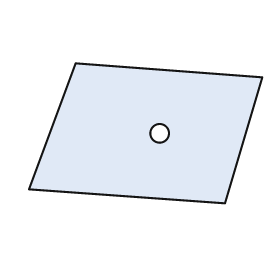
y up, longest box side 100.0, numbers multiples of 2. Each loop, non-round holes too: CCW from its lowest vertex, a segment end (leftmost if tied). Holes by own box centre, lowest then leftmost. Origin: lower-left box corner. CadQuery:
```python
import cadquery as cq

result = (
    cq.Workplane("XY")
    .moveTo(84.0, 0.0)
    .lineTo(100.0, 54.0)
    .lineTo(20.0, 60.0)
    .lineTo(0.0, 6.0)
    .close()
    .moveTo(56.0, 30.0)
    .circle(4.0)
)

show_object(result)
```